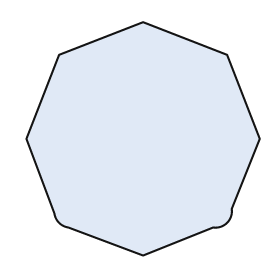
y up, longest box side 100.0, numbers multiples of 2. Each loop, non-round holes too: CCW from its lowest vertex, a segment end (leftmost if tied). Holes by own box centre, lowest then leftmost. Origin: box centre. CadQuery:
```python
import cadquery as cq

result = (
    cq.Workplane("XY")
    .moveTo(0.0, -50.0)
    .lineTo(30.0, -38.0)
    .threePointArc((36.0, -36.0), (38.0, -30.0))
    .lineTo(50.0, 0.0)
    .lineTo(36.0, 36.0)
    .lineTo(0.0, 50.0)
    .lineTo(-36.0, 36.0)
    .lineTo(-50.0, 0.0)
    .lineTo(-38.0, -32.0)
    .threePointArc((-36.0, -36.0), (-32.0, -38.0))
    .close()
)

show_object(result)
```